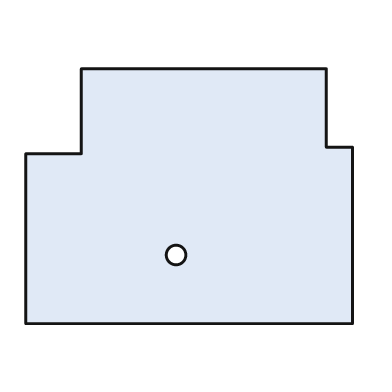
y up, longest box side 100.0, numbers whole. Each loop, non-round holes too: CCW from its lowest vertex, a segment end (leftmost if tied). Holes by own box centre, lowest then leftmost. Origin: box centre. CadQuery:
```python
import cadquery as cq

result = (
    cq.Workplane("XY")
    .moveTo(-50.0, -39.0)
    .lineTo(50.0, -39.0)
    .lineTo(50.0, 15.0)
    .lineTo(42.0, 15.0)
    .lineTo(42.0, 39.0)
    .lineTo(-33.0, 39.0)
    .lineTo(-33.0, 13.0)
    .lineTo(-50.0, 13.0)
    .close()
    .moveTo(-4.0, -18.0)
    .circle(3.0)
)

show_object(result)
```